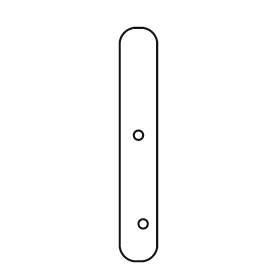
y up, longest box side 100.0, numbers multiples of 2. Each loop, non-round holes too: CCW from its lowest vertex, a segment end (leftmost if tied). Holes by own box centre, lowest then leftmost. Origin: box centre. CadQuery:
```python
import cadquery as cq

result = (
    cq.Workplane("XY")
    .moveTo(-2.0, -50.0)
    .lineTo(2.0, -50.0)
    .threePointArc((6.0, -48.0), (8.0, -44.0))
    .lineTo(8.0, 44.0)
    .threePointArc((6.0, 48.0), (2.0, 50.0))
    .lineTo(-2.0, 50.0)
    .threePointArc((-6.0, 48.0), (-8.0, 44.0))
    .lineTo(-8.0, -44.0)
    .threePointArc((-6.0, -48.0), (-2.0, -50.0))
    .close()
    .moveTo(2.0, -34.0)
    .circle(2.0)
    .moveTo(0.0, 4.0)
    .circle(2.0)
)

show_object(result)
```